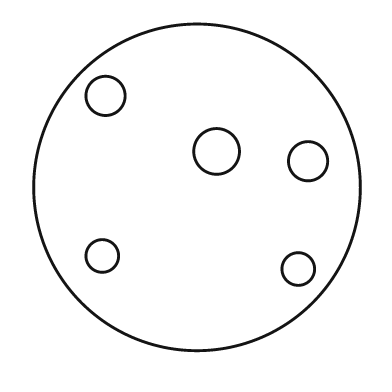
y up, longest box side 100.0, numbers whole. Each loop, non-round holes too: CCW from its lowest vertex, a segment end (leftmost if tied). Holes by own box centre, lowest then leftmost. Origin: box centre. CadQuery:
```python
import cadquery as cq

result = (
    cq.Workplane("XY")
    .moveTo(0.0, 0.0)
    .circle(50.0)
    .moveTo(31.0, -25.0)
    .circle(5.0)
    .moveTo(-29.0, -21.0)
    .circle(5.0)
    .moveTo(34.0, 8.0)
    .circle(6.0)
    .moveTo(6.0, 11.0)
    .circle(7.0)
    .moveTo(-28.0, 28.0)
    .circle(6.0)
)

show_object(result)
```